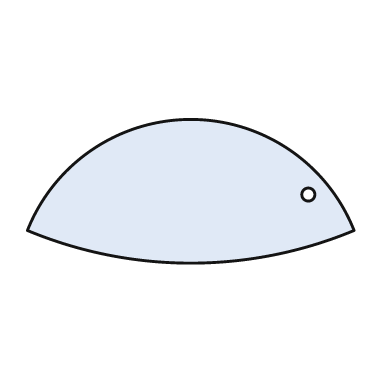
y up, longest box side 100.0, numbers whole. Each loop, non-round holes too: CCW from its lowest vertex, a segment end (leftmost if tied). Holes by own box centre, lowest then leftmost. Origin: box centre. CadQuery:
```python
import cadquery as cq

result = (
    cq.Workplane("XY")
    .moveTo(-50.0, -12.0)
    .threePointArc((0.0, -22.0), (50.0, -12.0))
    .threePointArc((0.0, 22.0), (-50.0, -12.0))
    .close()
    .moveTo(36.0, -1.0)
    .circle(2.0)
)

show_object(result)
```